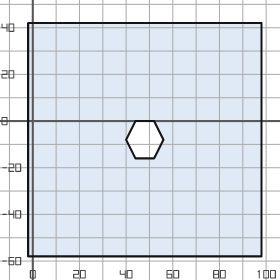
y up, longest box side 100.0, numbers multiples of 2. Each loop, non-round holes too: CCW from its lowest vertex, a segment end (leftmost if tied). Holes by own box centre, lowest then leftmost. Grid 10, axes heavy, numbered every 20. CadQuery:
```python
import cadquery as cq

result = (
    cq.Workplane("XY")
    .moveTo(-2.0, -58.0)
    .lineTo(98.0, -58.0)
    .lineTo(98.0, 42.0)
    .lineTo(-2.0, 42.0)
    .close()
    .moveTo(44.0, -16.0)
    .lineTo(52.0, -16.0)
    .lineTo(56.0, -8.0)
    .lineTo(52.0, 0.0)
    .lineTo(44.0, 0.0)
    .lineTo(40.0, -8.0)
    .close()
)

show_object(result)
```